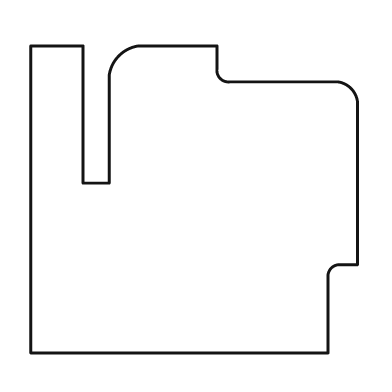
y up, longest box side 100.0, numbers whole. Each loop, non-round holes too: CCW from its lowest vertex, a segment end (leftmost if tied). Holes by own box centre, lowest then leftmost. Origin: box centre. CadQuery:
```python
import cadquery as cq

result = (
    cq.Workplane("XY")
    .moveTo(-50.0, -47.0)
    .lineTo(41.0, -47.0)
    .lineTo(41.0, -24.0)
    .threePointArc((42.0, -21.0), (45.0, -20.0))
    .lineTo(50.0, -20.0)
    .lineTo(50.0, 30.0)
    .threePointArc((48.0, 34.0), (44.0, 36.0))
    .lineTo(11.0, 36.0)
    .threePointArc((8.0, 37.0), (7.0, 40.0))
    .lineTo(7.0, 47.0)
    .lineTo(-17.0, 47.0)
    .threePointArc((-23.0, 44.0), (-26.0, 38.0))
    .lineTo(-26.0, 5.0)
    .lineTo(-34.0, 5.0)
    .lineTo(-34.0, 47.0)
    .lineTo(-50.0, 47.0)
    .close()
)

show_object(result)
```